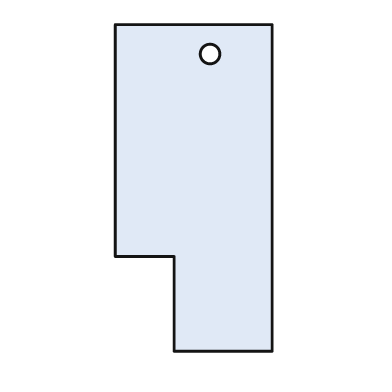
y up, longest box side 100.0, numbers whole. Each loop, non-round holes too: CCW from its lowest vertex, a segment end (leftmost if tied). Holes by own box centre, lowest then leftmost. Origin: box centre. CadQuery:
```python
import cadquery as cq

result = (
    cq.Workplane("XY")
    .moveTo(-6.0, -50.0)
    .lineTo(24.0, -50.0)
    .lineTo(24.0, 50.0)
    .lineTo(-24.0, 50.0)
    .lineTo(-24.0, -21.0)
    .lineTo(-6.0, -21.0)
    .close()
    .moveTo(5.0, 41.0)
    .circle(3.0)
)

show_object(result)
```